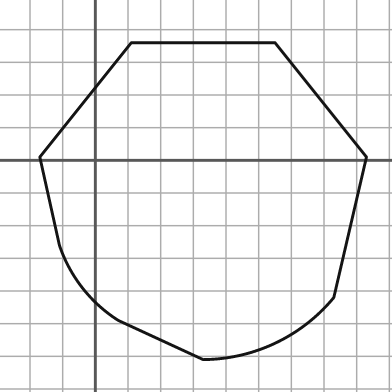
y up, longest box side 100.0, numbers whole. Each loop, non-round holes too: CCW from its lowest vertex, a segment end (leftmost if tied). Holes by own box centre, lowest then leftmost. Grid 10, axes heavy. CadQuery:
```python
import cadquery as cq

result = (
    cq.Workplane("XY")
    .moveTo(33.0, -61.0)
    .threePointArc((55.0, -56.0), (73.0, -42.0))
    .lineTo(83.0, 1.0)
    .lineTo(55.0, 36.0)
    .lineTo(11.0, 36.0)
    .lineTo(-17.0, 1.0)
    .lineTo(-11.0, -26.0)
    .threePointArc((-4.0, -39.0), (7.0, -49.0))
    .close()
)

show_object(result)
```